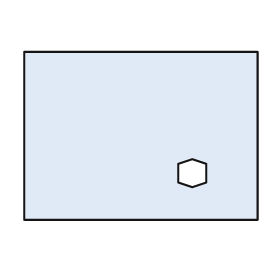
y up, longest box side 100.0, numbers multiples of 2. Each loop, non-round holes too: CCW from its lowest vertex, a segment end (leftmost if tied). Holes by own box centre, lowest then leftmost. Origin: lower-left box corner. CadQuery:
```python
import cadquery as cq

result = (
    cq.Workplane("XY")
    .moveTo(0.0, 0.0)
    .lineTo(100.0, 0.0)
    .lineTo(100.0, 72.0)
    .lineTo(0.0, 72.0)
    .close()
    .moveTo(72.0, 14.0)
    .lineTo(78.0, 16.0)
    .lineTo(78.0, 24.0)
    .lineTo(72.0, 26.0)
    .lineTo(66.0, 24.0)
    .lineTo(66.0, 16.0)
    .close()
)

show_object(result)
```